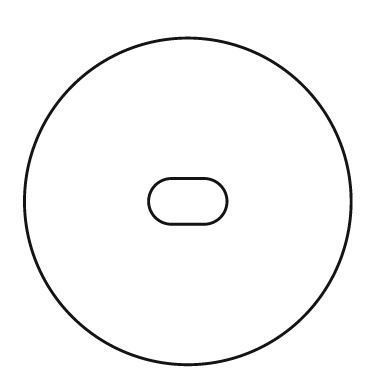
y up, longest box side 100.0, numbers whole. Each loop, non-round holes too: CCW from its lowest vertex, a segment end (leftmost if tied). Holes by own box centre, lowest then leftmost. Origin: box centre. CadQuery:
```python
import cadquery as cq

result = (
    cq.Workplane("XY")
    .moveTo(0.0, 0.0)
    .circle(50.0)
    .moveTo(-5.0, -7.0)
    .lineTo(5.0, -7.0)
    .threePointArc((12.0, 0.0), (5.0, 7.0))
    .lineTo(-5.0, 7.0)
    .threePointArc((-12.0, 0.0), (-5.0, -7.0))
    .close()
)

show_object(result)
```